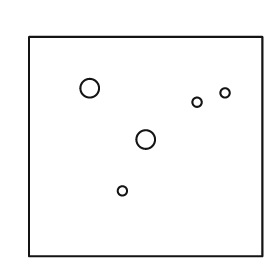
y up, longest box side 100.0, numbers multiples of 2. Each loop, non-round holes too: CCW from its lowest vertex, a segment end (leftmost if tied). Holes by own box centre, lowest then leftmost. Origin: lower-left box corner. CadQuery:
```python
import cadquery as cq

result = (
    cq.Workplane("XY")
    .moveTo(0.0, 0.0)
    .lineTo(100.0, 0.0)
    .lineTo(100.0, 94.0)
    .lineTo(0.0, 94.0)
    .close()
    .moveTo(40.0, 28.0)
    .circle(2.0)
    .moveTo(50.0, 50.0)
    .circle(4.0)
    .moveTo(72.0, 66.0)
    .circle(2.0)
    .moveTo(84.0, 70.0)
    .circle(2.0)
    .moveTo(26.0, 72.0)
    .circle(4.0)
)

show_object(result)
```